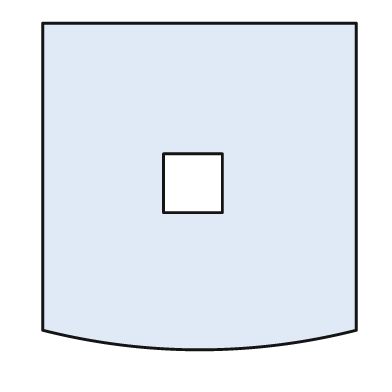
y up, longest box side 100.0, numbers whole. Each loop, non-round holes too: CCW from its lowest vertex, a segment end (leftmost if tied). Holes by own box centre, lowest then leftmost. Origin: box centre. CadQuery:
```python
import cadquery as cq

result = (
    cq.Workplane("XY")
    .moveTo(-48.0, -44.0)
    .threePointArc((0.0, -50.0), (48.0, -44.0))
    .lineTo(48.0, 50.0)
    .lineTo(-48.0, 50.0)
    .close()
    .moveTo(-11.0, -8.0)
    .lineTo(7.0, -8.0)
    .lineTo(7.0, 10.0)
    .lineTo(-11.0, 10.0)
    .close()
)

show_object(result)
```